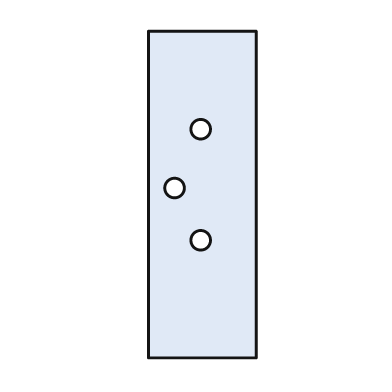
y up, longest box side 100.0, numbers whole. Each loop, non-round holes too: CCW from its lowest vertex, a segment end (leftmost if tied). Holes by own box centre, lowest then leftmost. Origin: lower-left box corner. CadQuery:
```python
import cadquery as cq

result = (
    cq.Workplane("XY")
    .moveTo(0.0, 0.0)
    .lineTo(33.0, 0.0)
    .lineTo(33.0, 100.0)
    .lineTo(0.0, 100.0)
    .close()
    .moveTo(16.0, 36.0)
    .circle(3.0)
    .moveTo(8.0, 52.0)
    .circle(3.0)
    .moveTo(16.0, 70.0)
    .circle(3.0)
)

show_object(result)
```